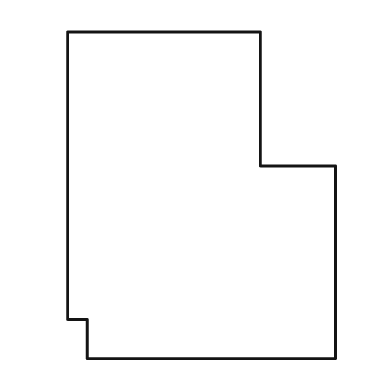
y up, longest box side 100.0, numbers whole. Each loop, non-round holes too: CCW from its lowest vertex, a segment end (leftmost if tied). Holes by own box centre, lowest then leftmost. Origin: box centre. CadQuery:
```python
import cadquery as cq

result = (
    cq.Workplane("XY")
    .moveTo(-35.0, -50.0)
    .lineTo(41.0, -50.0)
    .lineTo(41.0, 9.0)
    .lineTo(18.0, 9.0)
    .lineTo(18.0, 50.0)
    .lineTo(-41.0, 50.0)
    .lineTo(-41.0, -38.0)
    .lineTo(-35.0, -38.0)
    .close()
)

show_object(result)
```